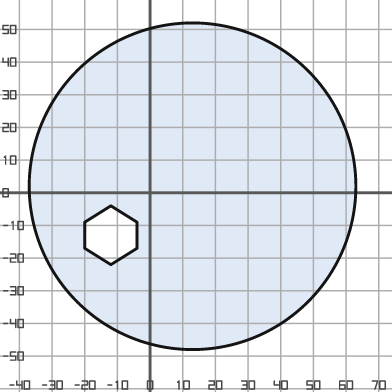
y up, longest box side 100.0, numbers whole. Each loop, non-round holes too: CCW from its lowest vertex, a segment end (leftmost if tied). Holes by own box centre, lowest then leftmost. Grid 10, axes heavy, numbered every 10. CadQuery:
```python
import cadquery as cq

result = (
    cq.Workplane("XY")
    .moveTo(13.0, 2.0)
    .circle(50.0)
    .moveTo(-12.0, -22.0)
    .lineTo(-4.0, -17.0)
    .lineTo(-4.0, -9.0)
    .lineTo(-12.0, -4.0)
    .lineTo(-20.0, -9.0)
    .lineTo(-20.0, -17.0)
    .close()
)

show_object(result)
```